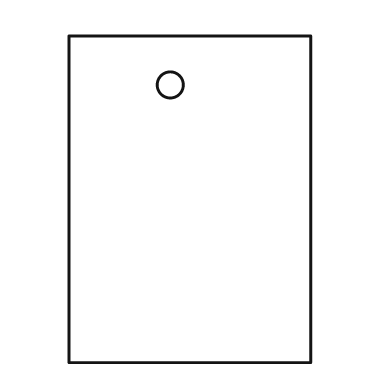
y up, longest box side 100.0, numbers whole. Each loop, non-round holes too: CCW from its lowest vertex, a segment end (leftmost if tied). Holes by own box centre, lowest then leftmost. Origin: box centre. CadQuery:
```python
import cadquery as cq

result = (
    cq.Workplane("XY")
    .moveTo(-37.0, -50.0)
    .lineTo(37.0, -50.0)
    .lineTo(37.0, 50.0)
    .lineTo(-37.0, 50.0)
    .close()
    .moveTo(-6.0, 35.0)
    .circle(4.0)
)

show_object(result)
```